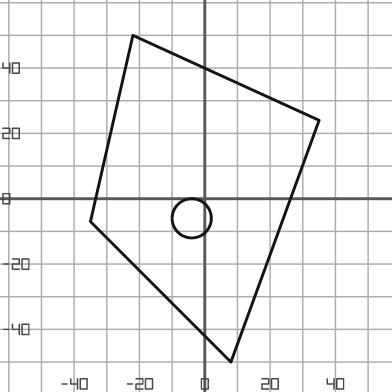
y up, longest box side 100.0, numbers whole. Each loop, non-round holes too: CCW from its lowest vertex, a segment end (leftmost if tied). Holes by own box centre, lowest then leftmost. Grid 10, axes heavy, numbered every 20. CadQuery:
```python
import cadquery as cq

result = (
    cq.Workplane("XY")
    .moveTo(8.0, -50.0)
    .lineTo(35.0, 24.0)
    .lineTo(-22.0, 50.0)
    .lineTo(-35.0, -7.0)
    .close()
    .moveTo(-4.0, -6.0)
    .circle(6.0)
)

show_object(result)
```